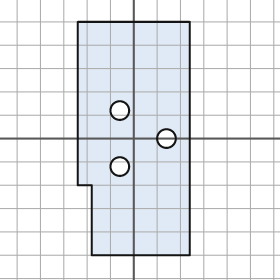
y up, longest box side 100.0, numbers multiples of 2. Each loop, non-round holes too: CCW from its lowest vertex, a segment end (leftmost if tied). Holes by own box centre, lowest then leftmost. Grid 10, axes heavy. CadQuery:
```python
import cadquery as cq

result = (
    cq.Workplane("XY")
    .moveTo(-18.0, -50.0)
    .lineTo(24.0, -50.0)
    .lineTo(24.0, 50.0)
    .lineTo(-24.0, 50.0)
    .lineTo(-24.0, -20.0)
    .lineTo(-18.0, -20.0)
    .close()
    .moveTo(-6.0, -12.0)
    .circle(4.0)
    .moveTo(14.0, 0.0)
    .circle(4.0)
    .moveTo(-6.0, 12.0)
    .circle(4.0)
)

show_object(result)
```